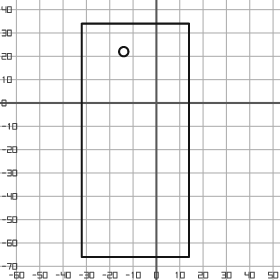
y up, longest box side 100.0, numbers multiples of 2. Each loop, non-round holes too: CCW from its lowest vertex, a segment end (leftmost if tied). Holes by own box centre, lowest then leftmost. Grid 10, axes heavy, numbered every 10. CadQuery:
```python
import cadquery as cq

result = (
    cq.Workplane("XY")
    .moveTo(-32.0, -66.0)
    .lineTo(14.0, -66.0)
    .lineTo(14.0, 34.0)
    .lineTo(-32.0, 34.0)
    .close()
    .moveTo(-14.0, 22.0)
    .circle(2.0)
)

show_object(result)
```